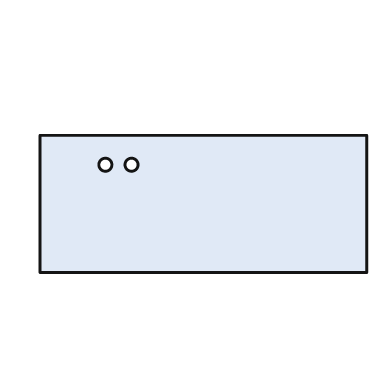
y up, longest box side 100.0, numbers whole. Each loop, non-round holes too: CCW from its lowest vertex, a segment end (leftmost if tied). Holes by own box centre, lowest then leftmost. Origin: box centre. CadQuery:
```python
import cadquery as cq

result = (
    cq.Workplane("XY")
    .moveTo(-50.0, -21.0)
    .lineTo(50.0, -21.0)
    .lineTo(50.0, 21.0)
    .lineTo(-50.0, 21.0)
    .close()
    .moveTo(-30.0, 12.0)
    .circle(2.0)
    .moveTo(-22.0, 12.0)
    .circle(2.0)
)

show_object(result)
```